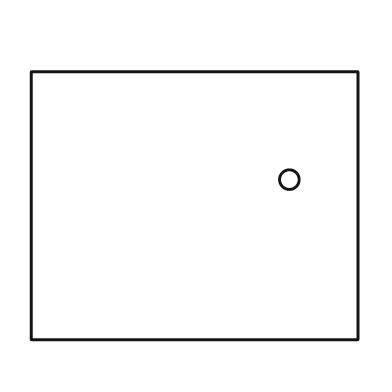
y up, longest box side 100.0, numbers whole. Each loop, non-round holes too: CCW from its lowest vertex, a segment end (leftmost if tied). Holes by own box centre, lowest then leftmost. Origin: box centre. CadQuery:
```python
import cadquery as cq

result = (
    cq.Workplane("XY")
    .moveTo(-50.0, -41.0)
    .lineTo(50.0, -41.0)
    .lineTo(50.0, 41.0)
    .lineTo(-50.0, 41.0)
    .close()
    .moveTo(29.0, 8.0)
    .circle(3.0)
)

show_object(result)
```